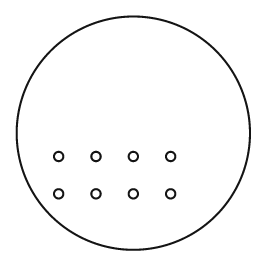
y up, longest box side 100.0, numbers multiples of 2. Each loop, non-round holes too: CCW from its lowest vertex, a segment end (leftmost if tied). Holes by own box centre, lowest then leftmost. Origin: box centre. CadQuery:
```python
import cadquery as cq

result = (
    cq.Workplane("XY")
    .moveTo(0.0, 0.0)
    .circle(50.0)
    .moveTo(-32.0, -26.0)
    .circle(2.0)
    .moveTo(-16.0, -26.0)
    .circle(2.0)
    .moveTo(0.0, -26.0)
    .circle(2.0)
    .moveTo(16.0, -26.0)
    .circle(2.0)
    .moveTo(-32.0, -10.0)
    .circle(2.0)
    .moveTo(-16.0, -10.0)
    .circle(2.0)
    .moveTo(0.0, -10.0)
    .circle(2.0)
    .moveTo(16.0, -10.0)
    .circle(2.0)
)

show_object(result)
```